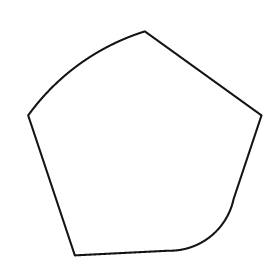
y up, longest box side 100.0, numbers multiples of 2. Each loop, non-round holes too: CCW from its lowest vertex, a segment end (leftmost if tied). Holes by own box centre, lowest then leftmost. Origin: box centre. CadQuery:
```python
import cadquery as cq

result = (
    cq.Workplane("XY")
    .moveTo(-30.0, -48.0)
    .lineTo(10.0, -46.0)
    .threePointArc((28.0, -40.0), (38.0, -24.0))
    .lineTo(50.0, 12.0)
    .lineTo(0.0, 48.0)
    .threePointArc((-28.0, 34.0), (-50.0, 12.0))
    .close()
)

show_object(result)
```